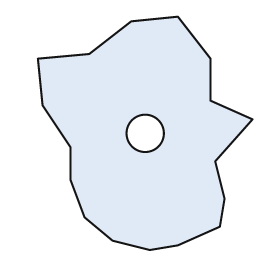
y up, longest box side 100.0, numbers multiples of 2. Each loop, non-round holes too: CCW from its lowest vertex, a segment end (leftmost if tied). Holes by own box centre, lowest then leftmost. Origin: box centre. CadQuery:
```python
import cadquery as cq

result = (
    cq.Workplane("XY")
    .moveTo(2.0, -50.0)
    .lineTo(14.0, -48.0)
    .lineTo(32.0, -40.0)
    .lineTo(34.0, -28.0)
    .lineTo(30.0, -12.0)
    .lineTo(46.0, 6.0)
    .lineTo(28.0, 14.0)
    .lineTo(28.0, 32.0)
    .lineTo(14.0, 50.0)
    .lineTo(-6.0, 48.0)
    .lineTo(-24.0, 34.0)
    .lineTo(-46.0, 32.0)
    .lineTo(-44.0, 12.0)
    .lineTo(-32.0, -6.0)
    .lineTo(-32.0, -20.0)
    .lineTo(-26.0, -36.0)
    .lineTo(-14.0, -46.0)
    .close()
    .moveTo(0.0, 0.0)
    .circle(8.0)
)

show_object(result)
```